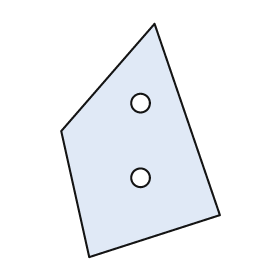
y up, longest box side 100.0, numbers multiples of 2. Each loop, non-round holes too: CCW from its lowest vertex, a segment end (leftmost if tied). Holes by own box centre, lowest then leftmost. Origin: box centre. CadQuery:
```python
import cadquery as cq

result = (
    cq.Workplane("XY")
    .moveTo(-22.0, -50.0)
    .lineTo(34.0, -32.0)
    .lineTo(6.0, 50.0)
    .lineTo(-34.0, 4.0)
    .close()
    .moveTo(0.0, -16.0)
    .circle(4.0)
    .moveTo(0.0, 16.0)
    .circle(4.0)
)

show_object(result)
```